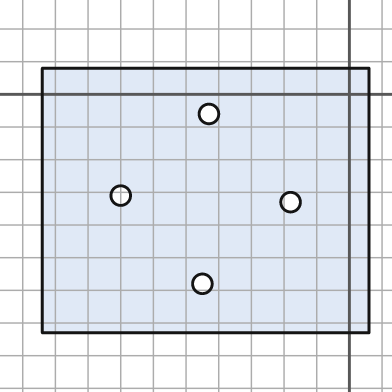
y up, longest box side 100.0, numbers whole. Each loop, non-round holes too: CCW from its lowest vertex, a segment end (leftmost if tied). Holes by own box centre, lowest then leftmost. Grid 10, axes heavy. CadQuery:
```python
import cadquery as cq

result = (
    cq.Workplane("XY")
    .moveTo(-94.0, -73.0)
    .lineTo(6.0, -73.0)
    .lineTo(6.0, 8.0)
    .lineTo(-94.0, 8.0)
    .close()
    .moveTo(-45.0, -58.0)
    .circle(3.0)
    .moveTo(-18.0, -33.0)
    .circle(3.0)
    .moveTo(-70.0, -31.0)
    .circle(3.0)
    .moveTo(-43.0, -6.0)
    .circle(3.0)
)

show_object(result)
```